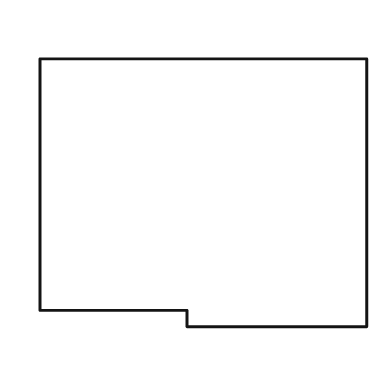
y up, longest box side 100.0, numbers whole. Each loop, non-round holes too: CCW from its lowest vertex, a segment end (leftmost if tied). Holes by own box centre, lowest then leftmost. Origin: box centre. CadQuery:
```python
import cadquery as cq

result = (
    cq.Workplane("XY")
    .moveTo(-5.0, -41.0)
    .lineTo(50.0, -41.0)
    .lineTo(50.0, 41.0)
    .lineTo(-50.0, 41.0)
    .lineTo(-50.0, -36.0)
    .lineTo(-5.0, -36.0)
    .close()
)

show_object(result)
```